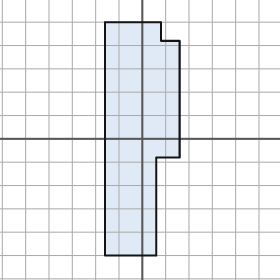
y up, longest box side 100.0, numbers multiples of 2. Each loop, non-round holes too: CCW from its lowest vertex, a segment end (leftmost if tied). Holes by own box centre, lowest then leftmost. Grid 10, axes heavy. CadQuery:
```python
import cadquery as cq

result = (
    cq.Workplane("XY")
    .moveTo(-16.0, -50.0)
    .lineTo(6.0, -50.0)
    .lineTo(6.0, -8.0)
    .lineTo(16.0, -8.0)
    .lineTo(16.0, 42.0)
    .lineTo(8.0, 42.0)
    .lineTo(8.0, 50.0)
    .lineTo(-16.0, 50.0)
    .close()
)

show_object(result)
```